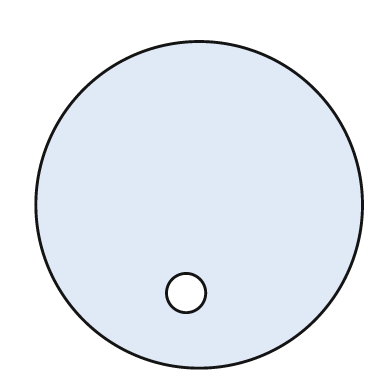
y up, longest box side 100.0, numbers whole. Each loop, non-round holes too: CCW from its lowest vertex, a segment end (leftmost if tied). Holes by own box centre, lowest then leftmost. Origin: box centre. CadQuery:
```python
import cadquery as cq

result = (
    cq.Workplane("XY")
    .moveTo(0.0, 0.0)
    .circle(50.0)
    .moveTo(-4.0, -27.0)
    .circle(6.0)
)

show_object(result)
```